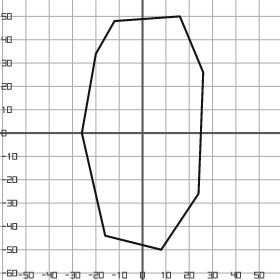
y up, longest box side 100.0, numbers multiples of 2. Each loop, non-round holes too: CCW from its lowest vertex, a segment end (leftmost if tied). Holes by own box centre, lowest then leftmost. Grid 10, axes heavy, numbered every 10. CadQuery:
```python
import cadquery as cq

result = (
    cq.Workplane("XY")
    .moveTo(8.0, -50.0)
    .lineTo(24.0, -26.0)
    .lineTo(26.0, 26.0)
    .lineTo(16.0, 50.0)
    .lineTo(-12.0, 48.0)
    .lineTo(-20.0, 34.0)
    .lineTo(-26.0, 0.0)
    .lineTo(-16.0, -44.0)
    .close()
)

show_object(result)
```